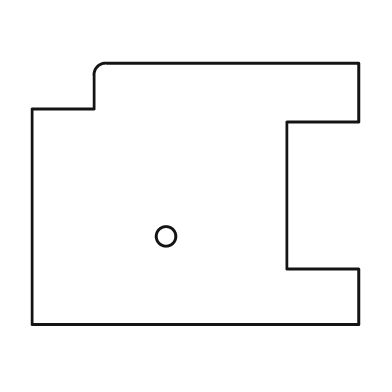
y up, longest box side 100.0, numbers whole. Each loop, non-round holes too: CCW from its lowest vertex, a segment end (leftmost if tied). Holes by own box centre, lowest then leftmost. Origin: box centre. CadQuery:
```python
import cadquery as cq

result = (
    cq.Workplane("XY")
    .moveTo(-50.0, -40.0)
    .lineTo(50.0, -40.0)
    .lineTo(50.0, -23.0)
    .lineTo(28.0, -23.0)
    .lineTo(28.0, 22.0)
    .lineTo(50.0, 22.0)
    .lineTo(50.0, 40.0)
    .lineTo(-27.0, 40.0)
    .threePointArc((-30.0, 39.0), (-31.0, 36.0))
    .lineTo(-31.0, 26.0)
    .lineTo(-50.0, 26.0)
    .close()
    .moveTo(-9.0, -13.0)
    .circle(3.0)
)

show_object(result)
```